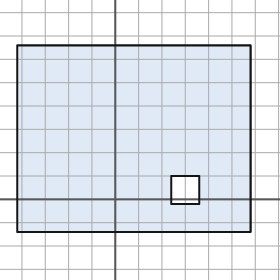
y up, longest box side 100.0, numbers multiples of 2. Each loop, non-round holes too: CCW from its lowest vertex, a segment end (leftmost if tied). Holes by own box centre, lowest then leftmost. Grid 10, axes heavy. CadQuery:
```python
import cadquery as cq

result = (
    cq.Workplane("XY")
    .moveTo(-42.0, -14.0)
    .lineTo(58.0, -14.0)
    .lineTo(58.0, 66.0)
    .lineTo(-42.0, 66.0)
    .close()
    .moveTo(24.0, -2.0)
    .lineTo(36.0, -2.0)
    .lineTo(36.0, 10.0)
    .lineTo(24.0, 10.0)
    .close()
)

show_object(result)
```